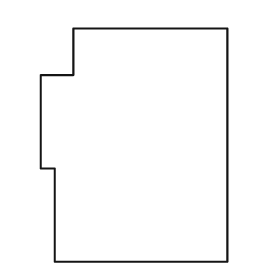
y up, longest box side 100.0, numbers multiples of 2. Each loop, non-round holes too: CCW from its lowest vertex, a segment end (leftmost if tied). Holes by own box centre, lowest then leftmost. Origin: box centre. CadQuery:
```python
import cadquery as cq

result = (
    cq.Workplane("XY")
    .moveTo(-34.0, -50.0)
    .lineTo(40.0, -50.0)
    .lineTo(40.0, 50.0)
    .lineTo(-26.0, 50.0)
    .lineTo(-26.0, 30.0)
    .lineTo(-40.0, 30.0)
    .lineTo(-40.0, -10.0)
    .lineTo(-34.0, -10.0)
    .close()
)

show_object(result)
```